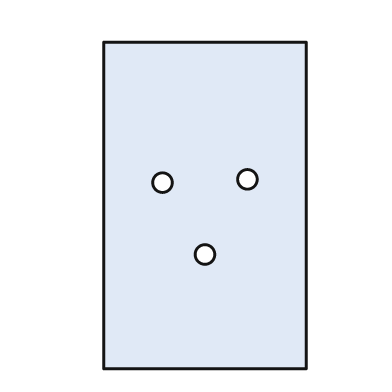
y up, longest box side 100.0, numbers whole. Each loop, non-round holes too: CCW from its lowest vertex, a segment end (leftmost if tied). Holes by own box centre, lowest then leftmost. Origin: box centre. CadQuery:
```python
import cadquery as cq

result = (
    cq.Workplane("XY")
    .moveTo(-31.0, -50.0)
    .lineTo(31.0, -50.0)
    .lineTo(31.0, 50.0)
    .lineTo(-31.0, 50.0)
    .close()
    .moveTo(0.0, -15.0)
    .circle(3.0)
    .moveTo(-13.0, 7.0)
    .circle(3.0)
    .moveTo(13.0, 8.0)
    .circle(3.0)
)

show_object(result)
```